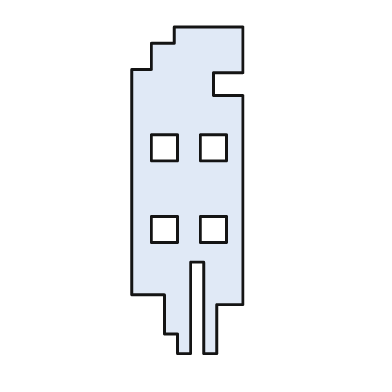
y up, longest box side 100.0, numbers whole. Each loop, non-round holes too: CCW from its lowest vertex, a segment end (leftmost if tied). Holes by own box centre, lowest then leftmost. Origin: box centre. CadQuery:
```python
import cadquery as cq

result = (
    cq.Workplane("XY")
    .moveTo(-3.0, -50.0)
    .lineTo(1.0, -50.0)
    .lineTo(1.0, -22.0)
    .lineTo(5.0, -22.0)
    .lineTo(5.0, -50.0)
    .lineTo(9.0, -50.0)
    .lineTo(9.0, -35.0)
    .lineTo(17.0, -35.0)
    .lineTo(17.0, 29.0)
    .lineTo(8.0, 29.0)
    .lineTo(8.0, 36.0)
    .lineTo(17.0, 36.0)
    .lineTo(17.0, 50.0)
    .lineTo(-4.0, 50.0)
    .lineTo(-4.0, 45.0)
    .lineTo(-11.0, 45.0)
    .lineTo(-11.0, 37.0)
    .lineTo(-17.0, 37.0)
    .lineTo(-17.0, -32.0)
    .lineTo(-7.0, -32.0)
    .lineTo(-7.0, -44.0)
    .lineTo(-3.0, -44.0)
    .close()
    .moveTo(-11.0, -16.0)
    .lineTo(-3.0, -16.0)
    .lineTo(-3.0, -8.0)
    .lineTo(-11.0, -8.0)
    .close()
    .moveTo(4.0, -16.0)
    .lineTo(12.0, -16.0)
    .lineTo(12.0, -8.0)
    .lineTo(4.0, -8.0)
    .close()
    .moveTo(-11.0, 9.0)
    .lineTo(-3.0, 9.0)
    .lineTo(-3.0, 17.0)
    .lineTo(-11.0, 17.0)
    .close()
    .moveTo(4.0, 9.0)
    .lineTo(12.0, 9.0)
    .lineTo(12.0, 17.0)
    .lineTo(4.0, 17.0)
    .close()
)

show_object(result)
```